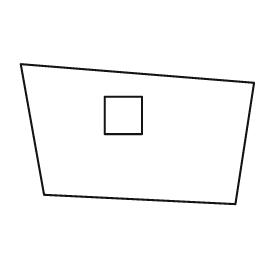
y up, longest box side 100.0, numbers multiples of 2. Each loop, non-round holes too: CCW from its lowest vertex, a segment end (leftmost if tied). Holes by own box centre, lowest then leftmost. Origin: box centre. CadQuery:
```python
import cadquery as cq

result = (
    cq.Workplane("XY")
    .moveTo(42.0, -30.0)
    .lineTo(50.0, 22.0)
    .lineTo(-50.0, 30.0)
    .lineTo(-40.0, -26.0)
    .close()
    .moveTo(-14.0, 0.0)
    .lineTo(2.0, 0.0)
    .lineTo(2.0, 16.0)
    .lineTo(-14.0, 16.0)
    .close()
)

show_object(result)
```